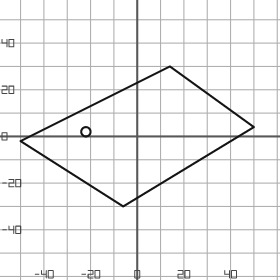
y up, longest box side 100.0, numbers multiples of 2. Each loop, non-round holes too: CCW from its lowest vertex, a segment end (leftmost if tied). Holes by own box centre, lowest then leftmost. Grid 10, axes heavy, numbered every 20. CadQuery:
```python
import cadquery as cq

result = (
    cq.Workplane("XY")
    .moveTo(-6.0, -30.0)
    .lineTo(50.0, 4.0)
    .lineTo(14.0, 30.0)
    .lineTo(-50.0, -2.0)
    .close()
    .moveTo(-22.0, 2.0)
    .circle(2.0)
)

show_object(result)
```